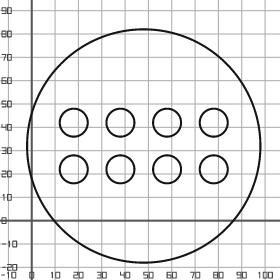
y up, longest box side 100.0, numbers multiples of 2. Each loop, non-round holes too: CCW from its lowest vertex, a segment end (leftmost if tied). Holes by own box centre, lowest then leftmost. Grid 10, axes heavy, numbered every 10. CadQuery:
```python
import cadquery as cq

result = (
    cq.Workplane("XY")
    .moveTo(48.0, 32.0)
    .circle(50.0)
    .moveTo(18.0, 22.0)
    .circle(6.0)
    .moveTo(38.0, 22.0)
    .circle(6.0)
    .moveTo(58.0, 22.0)
    .circle(6.0)
    .moveTo(78.0, 22.0)
    .circle(6.0)
    .moveTo(18.0, 42.0)
    .circle(6.0)
    .moveTo(38.0, 42.0)
    .circle(6.0)
    .moveTo(58.0, 42.0)
    .circle(6.0)
    .moveTo(78.0, 42.0)
    .circle(6.0)
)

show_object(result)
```